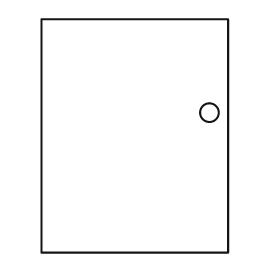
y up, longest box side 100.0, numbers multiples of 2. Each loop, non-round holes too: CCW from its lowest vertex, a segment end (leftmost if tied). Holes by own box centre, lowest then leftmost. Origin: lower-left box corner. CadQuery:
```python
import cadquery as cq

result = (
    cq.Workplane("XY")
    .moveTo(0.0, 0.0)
    .lineTo(80.0, 0.0)
    .lineTo(80.0, 100.0)
    .lineTo(0.0, 100.0)
    .close()
    .moveTo(72.0, 60.0)
    .circle(4.0)
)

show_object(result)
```